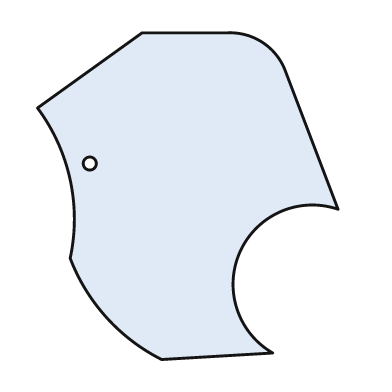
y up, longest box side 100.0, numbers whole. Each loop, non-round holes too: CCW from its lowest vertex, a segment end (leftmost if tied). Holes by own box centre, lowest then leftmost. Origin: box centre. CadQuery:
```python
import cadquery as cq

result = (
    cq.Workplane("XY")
    .moveTo(-8.0, -50.0)
    .lineTo(26.0, -48.0)
    .threePointArc((16.0, -17.0), (46.0, -4.0))
    .lineTo(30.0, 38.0)
    .threePointArc((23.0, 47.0), (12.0, 50.0))
    .lineTo(-14.0, 50.0)
    .lineTo(-46.0, 27.0)
    .threePointArc((-36.0, 5.0), (-36.0, -19.0))
    .threePointArc((-25.0, -37.0), (-8.0, -50.0))
    .close()
    .moveTo(-30.0, 10.0)
    .circle(2.0)
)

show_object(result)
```